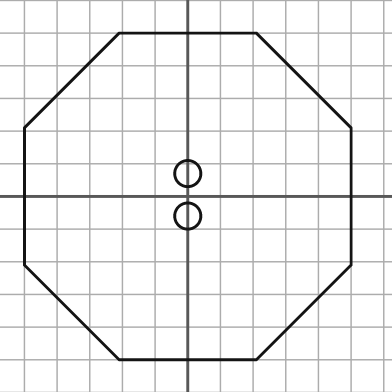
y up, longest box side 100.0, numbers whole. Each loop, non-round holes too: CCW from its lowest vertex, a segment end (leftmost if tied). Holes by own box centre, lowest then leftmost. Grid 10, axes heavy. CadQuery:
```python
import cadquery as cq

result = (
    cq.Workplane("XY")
    .moveTo(-21.0, -50.0)
    .lineTo(21.0, -50.0)
    .lineTo(50.0, -21.0)
    .lineTo(50.0, 21.0)
    .lineTo(21.0, 50.0)
    .lineTo(-21.0, 50.0)
    .lineTo(-50.0, 21.0)
    .lineTo(-50.0, -21.0)
    .close()
    .moveTo(0.0, -6.0)
    .circle(4.0)
    .moveTo(0.0, 7.0)
    .circle(4.0)
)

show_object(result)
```